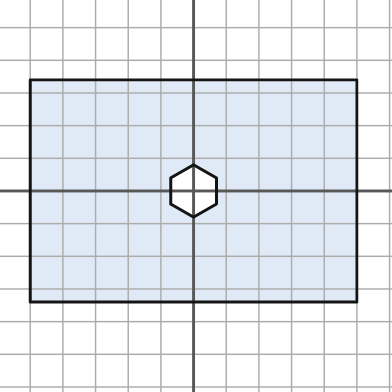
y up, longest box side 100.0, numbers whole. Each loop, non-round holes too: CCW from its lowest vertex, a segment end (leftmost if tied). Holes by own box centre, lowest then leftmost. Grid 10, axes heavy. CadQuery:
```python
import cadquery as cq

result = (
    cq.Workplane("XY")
    .moveTo(-50.0, -34.0)
    .lineTo(50.0, -34.0)
    .lineTo(50.0, 34.0)
    .lineTo(-50.0, 34.0)
    .close()
    .moveTo(0.0, -8.0)
    .lineTo(7.0, -4.0)
    .lineTo(7.0, 4.0)
    .lineTo(0.0, 8.0)
    .lineTo(-7.0, 4.0)
    .lineTo(-7.0, -4.0)
    .close()
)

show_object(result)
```